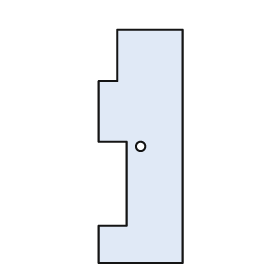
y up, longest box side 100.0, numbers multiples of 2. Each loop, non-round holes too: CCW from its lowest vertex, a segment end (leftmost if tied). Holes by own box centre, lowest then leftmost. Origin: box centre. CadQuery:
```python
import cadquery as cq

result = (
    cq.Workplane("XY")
    .moveTo(-18.0, -50.0)
    .lineTo(18.0, -50.0)
    .lineTo(18.0, 50.0)
    .lineTo(-10.0, 50.0)
    .lineTo(-10.0, 28.0)
    .lineTo(-18.0, 28.0)
    .lineTo(-18.0, 2.0)
    .lineTo(-6.0, 2.0)
    .lineTo(-6.0, -34.0)
    .lineTo(-18.0, -34.0)
    .close()
    .moveTo(0.0, 0.0)
    .circle(2.0)
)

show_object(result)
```